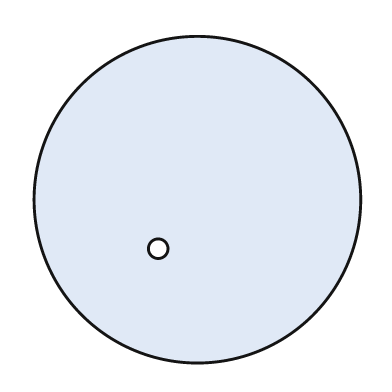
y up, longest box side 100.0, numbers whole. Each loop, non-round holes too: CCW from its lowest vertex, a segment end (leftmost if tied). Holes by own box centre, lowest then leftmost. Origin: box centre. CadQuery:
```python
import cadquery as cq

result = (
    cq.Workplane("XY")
    .moveTo(0.0, 0.0)
    .circle(50.0)
    .moveTo(-12.0, -15.0)
    .circle(3.0)
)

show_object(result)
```